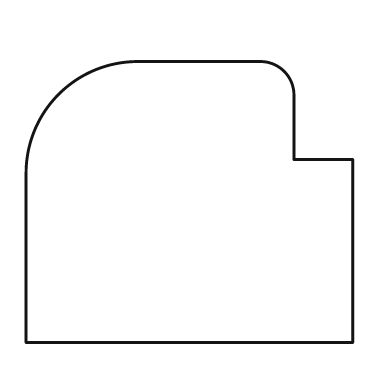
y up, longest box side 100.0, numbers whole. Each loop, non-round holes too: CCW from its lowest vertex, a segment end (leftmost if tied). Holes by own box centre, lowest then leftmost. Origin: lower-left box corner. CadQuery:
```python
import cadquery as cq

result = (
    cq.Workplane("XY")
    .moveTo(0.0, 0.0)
    .lineTo(100.0, 0.0)
    .lineTo(100.0, 56.0)
    .lineTo(82.0, 56.0)
    .lineTo(82.0, 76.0)
    .threePointArc((79.0, 83.0), (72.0, 86.0))
    .lineTo(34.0, 86.0)
    .threePointArc((10.0, 76.0), (0.0, 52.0))
    .close()
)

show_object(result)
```